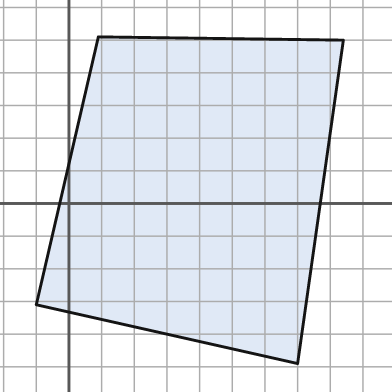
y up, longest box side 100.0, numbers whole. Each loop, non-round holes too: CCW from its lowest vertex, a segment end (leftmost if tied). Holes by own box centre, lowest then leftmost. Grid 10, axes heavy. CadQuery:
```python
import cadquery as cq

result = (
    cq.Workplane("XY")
    .moveTo(70.0, -49.0)
    .lineTo(84.0, 50.0)
    .lineTo(9.0, 51.0)
    .lineTo(-10.0, -31.0)
    .close()
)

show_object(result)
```